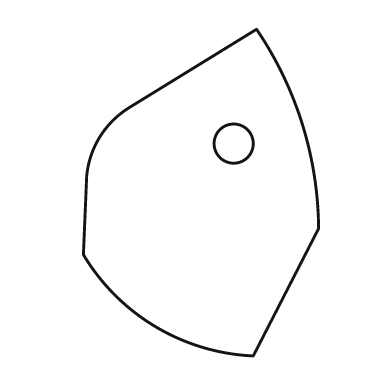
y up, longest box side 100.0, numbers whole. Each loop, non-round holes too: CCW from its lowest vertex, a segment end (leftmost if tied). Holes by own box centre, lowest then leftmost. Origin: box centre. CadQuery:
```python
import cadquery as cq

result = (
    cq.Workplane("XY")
    .moveTo(16.0, -50.0)
    .lineTo(36.0, -11.0)
    .threePointArc((31.0, 21.0), (17.0, 50.0))
    .lineTo(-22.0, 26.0)
    .threePointArc((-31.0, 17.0), (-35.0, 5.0))
    .lineTo(-36.0, -19.0)
    .threePointArc((-14.0, -41.0), (16.0, -50.0))
    .close()
    .moveTo(10.0, 15.0)
    .circle(6.0)
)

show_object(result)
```